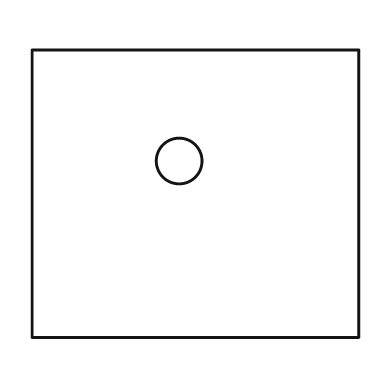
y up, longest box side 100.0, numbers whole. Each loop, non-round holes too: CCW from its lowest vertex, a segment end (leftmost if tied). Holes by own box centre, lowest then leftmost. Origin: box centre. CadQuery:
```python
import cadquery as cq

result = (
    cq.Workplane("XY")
    .moveTo(-50.0, -44.0)
    .lineTo(50.0, -44.0)
    .lineTo(50.0, 44.0)
    .lineTo(-50.0, 44.0)
    .close()
    .moveTo(-5.0, 10.0)
    .circle(7.0)
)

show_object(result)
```